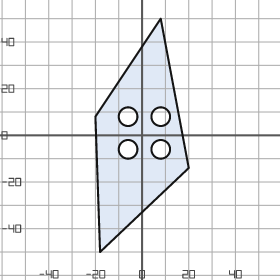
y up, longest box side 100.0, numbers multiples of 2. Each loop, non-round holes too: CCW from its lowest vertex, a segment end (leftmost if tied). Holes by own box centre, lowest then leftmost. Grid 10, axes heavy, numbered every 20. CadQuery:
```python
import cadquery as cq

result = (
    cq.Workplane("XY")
    .moveTo(-18.0, -50.0)
    .lineTo(20.0, -14.0)
    .lineTo(8.0, 50.0)
    .lineTo(-20.0, 8.0)
    .close()
    .moveTo(-6.0, -6.0)
    .circle(4.0)
    .moveTo(8.0, -6.0)
    .circle(4.0)
    .moveTo(-6.0, 8.0)
    .circle(4.0)
    .moveTo(8.0, 8.0)
    .circle(4.0)
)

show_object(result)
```